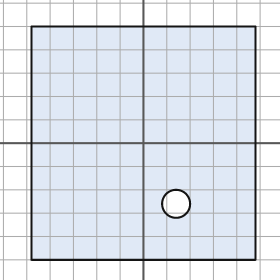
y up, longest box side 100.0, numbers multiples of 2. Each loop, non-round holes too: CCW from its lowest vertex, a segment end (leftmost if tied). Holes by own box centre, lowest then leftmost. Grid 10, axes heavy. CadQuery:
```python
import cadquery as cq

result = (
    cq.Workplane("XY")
    .moveTo(-48.0, -50.0)
    .lineTo(48.0, -50.0)
    .lineTo(48.0, 50.0)
    .lineTo(-48.0, 50.0)
    .close()
    .moveTo(14.0, -26.0)
    .circle(6.0)
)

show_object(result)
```